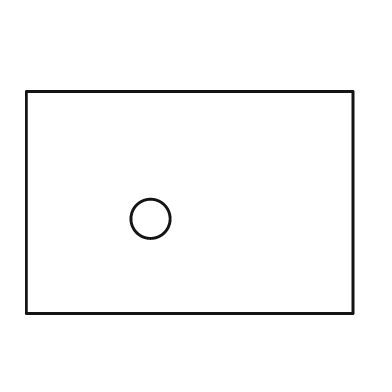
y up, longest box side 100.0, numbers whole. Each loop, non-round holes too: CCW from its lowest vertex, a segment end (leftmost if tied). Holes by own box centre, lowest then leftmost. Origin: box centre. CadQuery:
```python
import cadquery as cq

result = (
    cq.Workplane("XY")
    .moveTo(-50.0, -34.0)
    .lineTo(50.0, -34.0)
    .lineTo(50.0, 34.0)
    .lineTo(-50.0, 34.0)
    .close()
    .moveTo(-12.0, -5.0)
    .circle(6.0)
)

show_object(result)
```